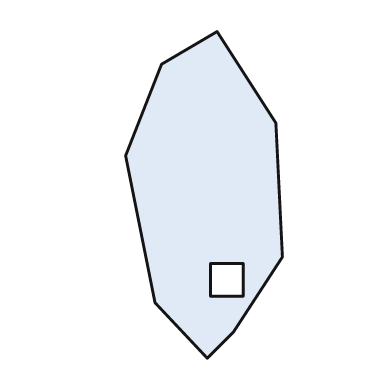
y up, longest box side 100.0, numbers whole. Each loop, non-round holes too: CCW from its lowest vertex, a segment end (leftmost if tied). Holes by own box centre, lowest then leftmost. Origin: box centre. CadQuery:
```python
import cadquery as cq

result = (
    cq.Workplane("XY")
    .moveTo(1.0, -50.0)
    .lineTo(9.0, -42.0)
    .lineTo(24.0, -19.0)
    .lineTo(22.0, 22.0)
    .lineTo(4.0, 50.0)
    .lineTo(-13.0, 40.0)
    .lineTo(-24.0, 12.0)
    .lineTo(-15.0, -33.0)
    .close()
    .moveTo(2.0, -31.0)
    .lineTo(12.0, -31.0)
    .lineTo(12.0, -21.0)
    .lineTo(2.0, -21.0)
    .close()
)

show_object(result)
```